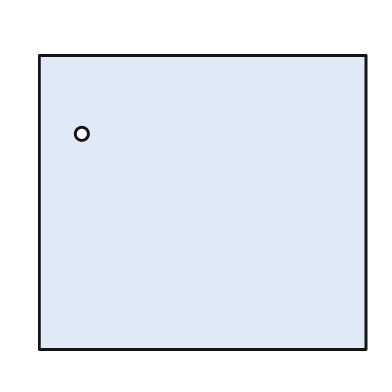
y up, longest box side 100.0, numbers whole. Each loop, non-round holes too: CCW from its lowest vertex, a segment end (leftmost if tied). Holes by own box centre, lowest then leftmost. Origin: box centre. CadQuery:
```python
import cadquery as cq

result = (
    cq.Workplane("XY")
    .moveTo(-50.0, -45.0)
    .lineTo(50.0, -45.0)
    .lineTo(50.0, 45.0)
    .lineTo(-50.0, 45.0)
    .close()
    .moveTo(-37.0, 21.0)
    .circle(2.0)
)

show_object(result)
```